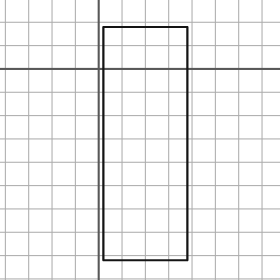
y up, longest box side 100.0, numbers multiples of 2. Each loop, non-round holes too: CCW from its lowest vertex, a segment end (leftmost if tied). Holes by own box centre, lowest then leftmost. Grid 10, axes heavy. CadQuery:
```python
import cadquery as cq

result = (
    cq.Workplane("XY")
    .moveTo(2.0, -82.0)
    .lineTo(38.0, -82.0)
    .lineTo(38.0, 18.0)
    .lineTo(2.0, 18.0)
    .close()
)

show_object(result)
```